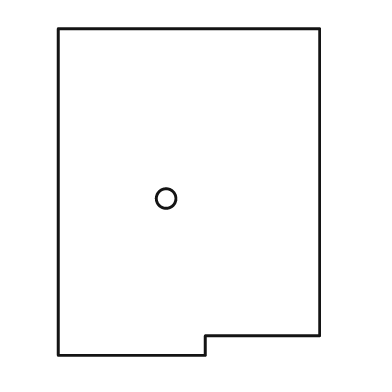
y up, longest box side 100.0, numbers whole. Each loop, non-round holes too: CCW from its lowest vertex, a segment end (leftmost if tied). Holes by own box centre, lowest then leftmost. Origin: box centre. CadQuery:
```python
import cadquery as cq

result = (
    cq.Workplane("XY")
    .moveTo(-40.0, -50.0)
    .lineTo(5.0, -50.0)
    .lineTo(5.0, -44.0)
    .lineTo(40.0, -44.0)
    .lineTo(40.0, 50.0)
    .lineTo(-40.0, 50.0)
    .close()
    .moveTo(-7.0, -2.0)
    .circle(3.0)
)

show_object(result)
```